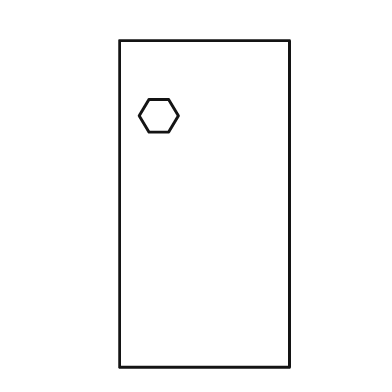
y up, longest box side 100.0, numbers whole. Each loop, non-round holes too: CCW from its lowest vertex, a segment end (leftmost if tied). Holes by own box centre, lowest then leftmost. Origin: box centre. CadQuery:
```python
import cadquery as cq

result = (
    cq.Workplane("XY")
    .moveTo(-26.0, -50.0)
    .lineTo(26.0, -50.0)
    .lineTo(26.0, 50.0)
    .lineTo(-26.0, 50.0)
    .close()
    .moveTo(-17.0, 22.0)
    .lineTo(-11.0, 22.0)
    .lineTo(-8.0, 27.0)
    .lineTo(-11.0, 32.0)
    .lineTo(-17.0, 32.0)
    .lineTo(-20.0, 27.0)
    .close()
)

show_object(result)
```